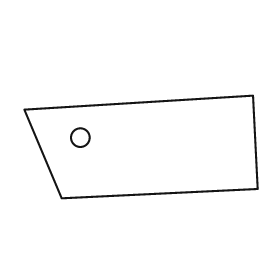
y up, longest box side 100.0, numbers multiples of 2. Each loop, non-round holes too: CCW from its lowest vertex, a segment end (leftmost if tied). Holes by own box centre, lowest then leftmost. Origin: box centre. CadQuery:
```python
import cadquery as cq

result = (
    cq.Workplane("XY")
    .moveTo(-34.0, -22.0)
    .lineTo(50.0, -18.0)
    .lineTo(48.0, 22.0)
    .lineTo(-50.0, 16.0)
    .close()
    .moveTo(-26.0, 4.0)
    .circle(4.0)
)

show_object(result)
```